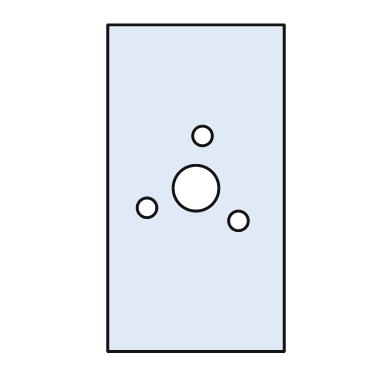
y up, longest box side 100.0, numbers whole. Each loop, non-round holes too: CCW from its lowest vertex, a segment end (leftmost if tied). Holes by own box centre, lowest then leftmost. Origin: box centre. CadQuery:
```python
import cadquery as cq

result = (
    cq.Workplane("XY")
    .moveTo(-27.0, -50.0)
    .lineTo(27.0, -50.0)
    .lineTo(27.0, 50.0)
    .lineTo(-27.0, 50.0)
    .close()
    .moveTo(13.0, -10.0)
    .circle(3.0)
    .moveTo(-15.0, -6.0)
    .circle(3.0)
    .moveTo(0.0, 0.0)
    .circle(7.0)
    .moveTo(2.0, 16.0)
    .circle(3.0)
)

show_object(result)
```